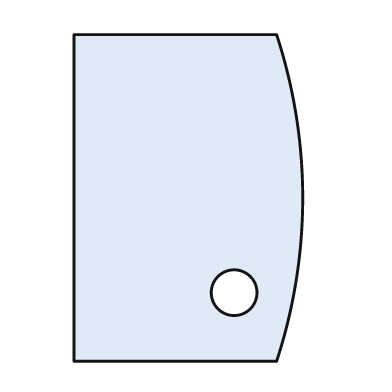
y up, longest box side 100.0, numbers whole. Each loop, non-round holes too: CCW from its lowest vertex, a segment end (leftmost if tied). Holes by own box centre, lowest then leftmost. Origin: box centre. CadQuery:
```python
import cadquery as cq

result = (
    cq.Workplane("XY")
    .moveTo(-35.0, -50.0)
    .lineTo(27.0, -50.0)
    .threePointArc((35.0, 0.0), (27.0, 50.0))
    .lineTo(-35.0, 50.0)
    .close()
    .moveTo(14.0, -29.0)
    .circle(7.0)
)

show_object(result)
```